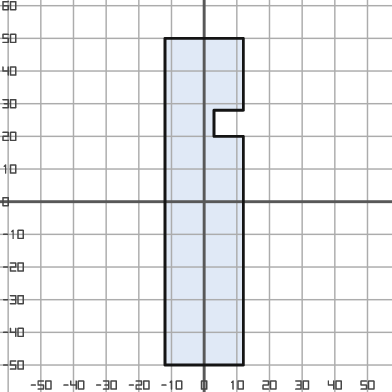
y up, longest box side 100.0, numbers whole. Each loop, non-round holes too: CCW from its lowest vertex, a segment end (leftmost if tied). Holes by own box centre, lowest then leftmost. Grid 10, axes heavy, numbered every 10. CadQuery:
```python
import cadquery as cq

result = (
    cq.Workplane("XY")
    .moveTo(-12.0, -50.0)
    .lineTo(12.0, -50.0)
    .lineTo(12.0, 20.0)
    .lineTo(3.0, 20.0)
    .lineTo(3.0, 28.0)
    .lineTo(12.0, 28.0)
    .lineTo(12.0, 50.0)
    .lineTo(-12.0, 50.0)
    .close()
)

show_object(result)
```